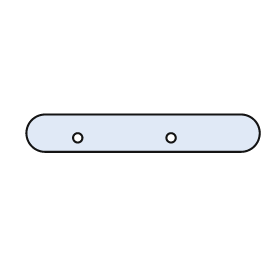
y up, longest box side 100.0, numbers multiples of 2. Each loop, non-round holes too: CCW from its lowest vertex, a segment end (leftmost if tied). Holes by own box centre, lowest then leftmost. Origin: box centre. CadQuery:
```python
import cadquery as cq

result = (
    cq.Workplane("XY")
    .moveTo(-42.0, -8.0)
    .lineTo(42.0, -8.0)
    .threePointArc((50.0, 0.0), (42.0, 8.0))
    .lineTo(-42.0, 8.0)
    .threePointArc((-50.0, 0.0), (-42.0, -8.0))
    .close()
    .moveTo(-28.0, -2.0)
    .circle(2.0)
    .moveTo(12.0, -2.0)
    .circle(2.0)
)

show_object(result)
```